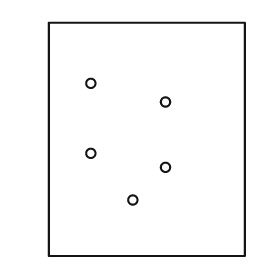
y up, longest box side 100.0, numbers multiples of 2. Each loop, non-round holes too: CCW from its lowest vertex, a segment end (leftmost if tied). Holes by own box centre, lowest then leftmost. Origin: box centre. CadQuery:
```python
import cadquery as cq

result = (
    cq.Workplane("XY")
    .moveTo(-42.0, -50.0)
    .lineTo(42.0, -50.0)
    .lineTo(42.0, 50.0)
    .lineTo(-42.0, 50.0)
    .close()
    .moveTo(-6.0, -26.0)
    .circle(2.0)
    .moveTo(8.0, -12.0)
    .circle(2.0)
    .moveTo(-24.0, -6.0)
    .circle(2.0)
    .moveTo(8.0, 16.0)
    .circle(2.0)
    .moveTo(-24.0, 24.0)
    .circle(2.0)
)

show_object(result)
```